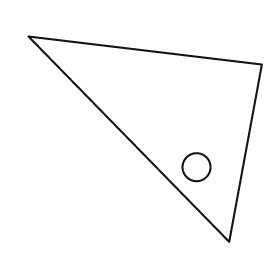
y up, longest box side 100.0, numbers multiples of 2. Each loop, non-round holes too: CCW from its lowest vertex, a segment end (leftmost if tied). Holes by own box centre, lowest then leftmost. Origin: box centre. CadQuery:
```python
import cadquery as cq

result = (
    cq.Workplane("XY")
    .moveTo(36.0, -44.0)
    .lineTo(50.0, 32.0)
    .lineTo(-50.0, 44.0)
    .close()
    .moveTo(22.0, -12.0)
    .circle(6.0)
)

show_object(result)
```